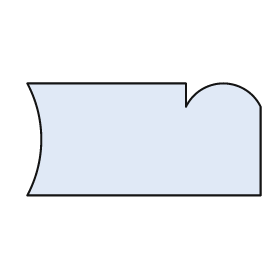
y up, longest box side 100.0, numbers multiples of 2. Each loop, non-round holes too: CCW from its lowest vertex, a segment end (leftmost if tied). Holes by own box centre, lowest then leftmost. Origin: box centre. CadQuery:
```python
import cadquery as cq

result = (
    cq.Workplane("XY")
    .moveTo(-50.0, -24.0)
    .lineTo(50.0, -24.0)
    .lineTo(50.0, 14.0)
    .threePointArc((34.0, 24.0), (18.0, 14.0))
    .lineTo(18.0, 24.0)
    .lineTo(-50.0, 24.0)
    .threePointArc((-44.0, 0.0), (-50.0, -24.0))
    .close()
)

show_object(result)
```